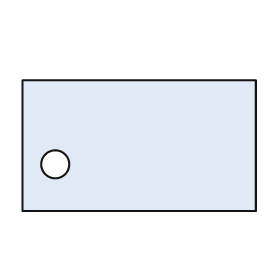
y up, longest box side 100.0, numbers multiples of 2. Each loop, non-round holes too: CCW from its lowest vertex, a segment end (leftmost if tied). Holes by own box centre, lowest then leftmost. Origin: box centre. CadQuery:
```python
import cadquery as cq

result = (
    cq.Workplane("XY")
    .moveTo(-50.0, -28.0)
    .lineTo(50.0, -28.0)
    .lineTo(50.0, 28.0)
    .lineTo(-50.0, 28.0)
    .close()
    .moveTo(-36.0, -8.0)
    .circle(6.0)
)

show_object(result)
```